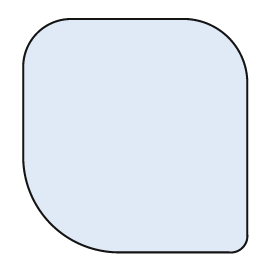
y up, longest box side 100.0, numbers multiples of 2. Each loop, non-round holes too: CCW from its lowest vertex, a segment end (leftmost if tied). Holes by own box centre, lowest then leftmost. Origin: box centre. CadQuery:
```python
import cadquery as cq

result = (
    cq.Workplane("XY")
    .moveTo(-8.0, -50.0)
    .lineTo(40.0, -50.0)
    .threePointArc((46.0, -48.0), (48.0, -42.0))
    .lineTo(48.0, 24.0)
    .threePointArc((40.0, 42.0), (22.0, 50.0))
    .lineTo(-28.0, 50.0)
    .threePointArc((-42.0, 44.0), (-48.0, 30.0))
    .lineTo(-48.0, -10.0)
    .threePointArc((-36.0, -38.0), (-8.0, -50.0))
    .close()
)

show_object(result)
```